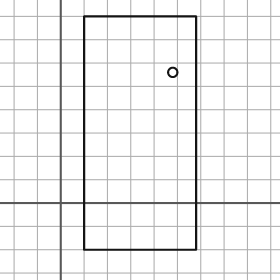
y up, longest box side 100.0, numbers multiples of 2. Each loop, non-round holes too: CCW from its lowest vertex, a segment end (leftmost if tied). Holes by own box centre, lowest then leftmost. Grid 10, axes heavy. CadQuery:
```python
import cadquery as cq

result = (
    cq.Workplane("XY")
    .moveTo(10.0, -20.0)
    .lineTo(58.0, -20.0)
    .lineTo(58.0, 80.0)
    .lineTo(10.0, 80.0)
    .close()
    .moveTo(48.0, 56.0)
    .circle(2.0)
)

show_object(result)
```